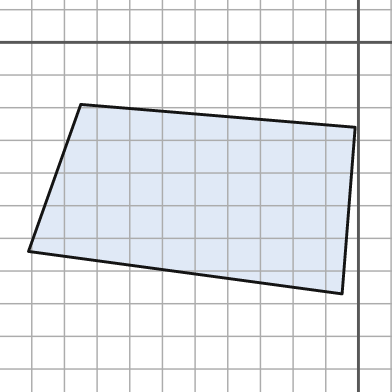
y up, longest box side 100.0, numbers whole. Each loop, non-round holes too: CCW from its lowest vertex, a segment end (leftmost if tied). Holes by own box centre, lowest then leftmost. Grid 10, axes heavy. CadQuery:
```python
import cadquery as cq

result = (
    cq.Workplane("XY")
    .moveTo(-5.0, -77.0)
    .lineTo(-1.0, -26.0)
    .lineTo(-85.0, -19.0)
    .lineTo(-101.0, -64.0)
    .close()
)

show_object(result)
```